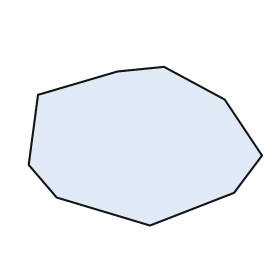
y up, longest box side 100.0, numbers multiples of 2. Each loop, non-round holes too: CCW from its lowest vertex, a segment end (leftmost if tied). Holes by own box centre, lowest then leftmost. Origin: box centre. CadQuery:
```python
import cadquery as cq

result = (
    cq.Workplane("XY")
    .moveTo(2.0, -34.0)
    .lineTo(38.0, -20.0)
    .lineTo(50.0, -4.0)
    .lineTo(34.0, 20.0)
    .lineTo(8.0, 34.0)
    .lineTo(-12.0, 32.0)
    .lineTo(-46.0, 22.0)
    .lineTo(-50.0, -8.0)
    .lineTo(-38.0, -22.0)
    .close()
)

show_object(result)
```